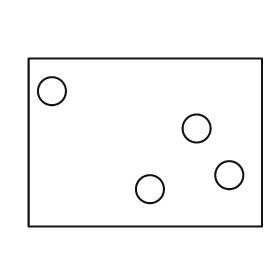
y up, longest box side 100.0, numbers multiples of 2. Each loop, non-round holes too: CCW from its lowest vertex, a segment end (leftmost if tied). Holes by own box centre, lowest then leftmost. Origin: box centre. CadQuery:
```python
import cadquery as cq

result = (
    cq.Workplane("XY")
    .moveTo(-50.0, -36.0)
    .lineTo(50.0, -36.0)
    .lineTo(50.0, 36.0)
    .lineTo(-50.0, 36.0)
    .close()
    .moveTo(2.0, -20.0)
    .circle(6.0)
    .moveTo(36.0, -14.0)
    .circle(6.0)
    .moveTo(22.0, 6.0)
    .circle(6.0)
    .moveTo(-40.0, 22.0)
    .circle(6.0)
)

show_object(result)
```